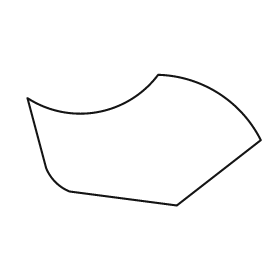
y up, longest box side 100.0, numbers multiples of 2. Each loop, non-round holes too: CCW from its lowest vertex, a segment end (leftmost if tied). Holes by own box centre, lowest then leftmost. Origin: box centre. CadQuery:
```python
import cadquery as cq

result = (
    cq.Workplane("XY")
    .moveTo(14.0, -28.0)
    .lineTo(50.0, 0.0)
    .threePointArc((32.0, 20.0), (6.0, 28.0))
    .threePointArc((-20.0, 12.0), (-50.0, 18.0))
    .lineTo(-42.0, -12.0)
    .threePointArc((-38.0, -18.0), (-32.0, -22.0))
    .close()
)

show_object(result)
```